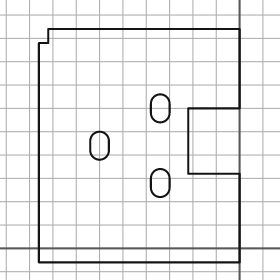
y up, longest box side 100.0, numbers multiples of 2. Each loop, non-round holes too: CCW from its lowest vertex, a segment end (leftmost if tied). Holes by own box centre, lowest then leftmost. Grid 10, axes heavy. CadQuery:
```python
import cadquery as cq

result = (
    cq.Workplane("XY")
    .moveTo(-86.0, -6.0)
    .lineTo(0.0, -6.0)
    .lineTo(0.0, 32.0)
    .lineTo(-22.0, 32.0)
    .lineTo(-22.0, 60.0)
    .lineTo(0.0, 60.0)
    .lineTo(0.0, 94.0)
    .lineTo(-82.0, 94.0)
    .lineTo(-82.0, 88.0)
    .lineTo(-86.0, 88.0)
    .close()
    .moveTo(-38.0, 26.0)
    .threePointArc((-34.0, 22.0), (-30.0, 26.0))
    .lineTo(-30.0, 30.0)
    .threePointArc((-34.0, 34.0), (-38.0, 30.0))
    .close()
    .moveTo(-64.0, 42.0)
    .threePointArc((-60.0, 38.0), (-56.0, 42.0))
    .lineTo(-56.0, 46.0)
    .threePointArc((-60.0, 50.0), (-64.0, 46.0))
    .close()
    .moveTo(-38.0, 58.0)
    .threePointArc((-34.0, 54.0), (-30.0, 58.0))
    .lineTo(-30.0, 62.0)
    .threePointArc((-34.0, 66.0), (-38.0, 62.0))
    .close()
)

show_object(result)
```